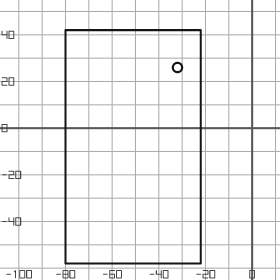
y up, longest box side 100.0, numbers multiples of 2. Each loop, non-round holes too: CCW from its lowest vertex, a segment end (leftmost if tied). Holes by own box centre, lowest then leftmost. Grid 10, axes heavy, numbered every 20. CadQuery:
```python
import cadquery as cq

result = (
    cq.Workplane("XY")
    .moveTo(-80.0, -58.0)
    .lineTo(-22.0, -58.0)
    .lineTo(-22.0, 42.0)
    .lineTo(-80.0, 42.0)
    .close()
    .moveTo(-32.0, 26.0)
    .circle(2.0)
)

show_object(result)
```